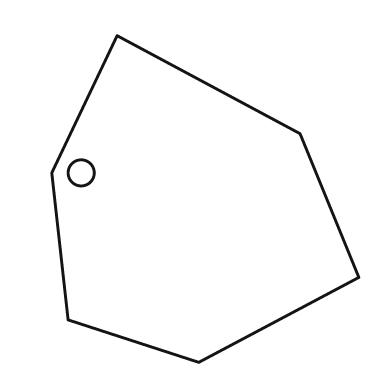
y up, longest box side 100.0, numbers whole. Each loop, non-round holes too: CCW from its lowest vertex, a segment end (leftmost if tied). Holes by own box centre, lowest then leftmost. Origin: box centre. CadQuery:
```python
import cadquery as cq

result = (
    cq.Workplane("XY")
    .moveTo(-2.0, -50.0)
    .lineTo(47.0, -24.0)
    .lineTo(29.0, 20.0)
    .lineTo(-27.0, 50.0)
    .lineTo(-47.0, 8.0)
    .lineTo(-42.0, -37.0)
    .close()
    .moveTo(-38.0, 8.0)
    .circle(4.0)
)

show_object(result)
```